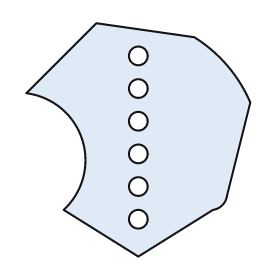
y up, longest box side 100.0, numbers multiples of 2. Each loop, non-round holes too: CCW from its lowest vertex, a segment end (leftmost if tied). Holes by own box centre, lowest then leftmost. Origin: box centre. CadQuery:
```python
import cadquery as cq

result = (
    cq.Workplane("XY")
    .moveTo(0.0, -50.0)
    .lineTo(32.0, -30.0)
    .threePointArc((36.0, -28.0), (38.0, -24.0))
    .lineTo(48.0, 16.0)
    .threePointArc((38.0, 32.0), (24.0, 44.0))
    .lineTo(-18.0, 50.0)
    .lineTo(-48.0, 20.0)
    .threePointArc((-24.0, 0.0), (-32.0, -30.0))
    .close()
    .moveTo(0.0, -34.0)
    .circle(4.0)
    .moveTo(0.0, -20.0)
    .circle(4.0)
    .moveTo(0.0, -6.0)
    .circle(4.0)
    .moveTo(0.0, 8.0)
    .circle(4.0)
    .moveTo(0.0, 22.0)
    .circle(4.0)
    .moveTo(0.0, 36.0)
    .circle(4.0)
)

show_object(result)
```